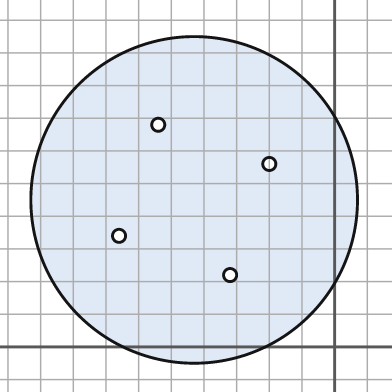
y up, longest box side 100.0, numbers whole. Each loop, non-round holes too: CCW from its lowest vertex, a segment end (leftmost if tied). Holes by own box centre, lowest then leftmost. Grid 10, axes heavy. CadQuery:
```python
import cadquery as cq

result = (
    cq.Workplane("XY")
    .moveTo(-43.0, 45.0)
    .circle(50.0)
    .moveTo(-32.0, 22.0)
    .circle(2.0)
    .moveTo(-66.0, 34.0)
    .circle(2.0)
    .moveTo(-20.0, 56.0)
    .circle(2.0)
    .moveTo(-54.0, 68.0)
    .circle(2.0)
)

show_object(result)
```